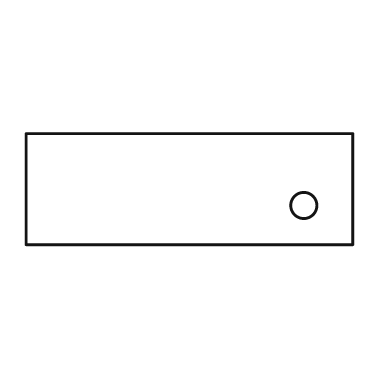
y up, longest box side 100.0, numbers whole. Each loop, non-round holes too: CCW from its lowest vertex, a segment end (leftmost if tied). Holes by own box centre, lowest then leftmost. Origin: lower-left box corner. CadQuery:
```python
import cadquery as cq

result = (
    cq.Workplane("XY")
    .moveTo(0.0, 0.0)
    .lineTo(100.0, 0.0)
    .lineTo(100.0, 34.0)
    .lineTo(0.0, 34.0)
    .close()
    .moveTo(85.0, 12.0)
    .circle(4.0)
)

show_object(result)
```